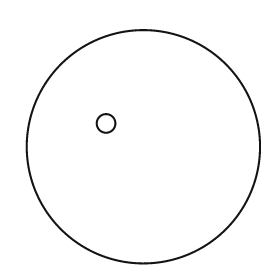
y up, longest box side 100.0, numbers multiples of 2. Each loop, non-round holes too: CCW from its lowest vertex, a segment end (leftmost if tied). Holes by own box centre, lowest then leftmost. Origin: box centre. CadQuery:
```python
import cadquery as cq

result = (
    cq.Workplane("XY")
    .moveTo(0.0, 0.0)
    .circle(50.0)
    .moveTo(-16.0, 10.0)
    .circle(4.0)
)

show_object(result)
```